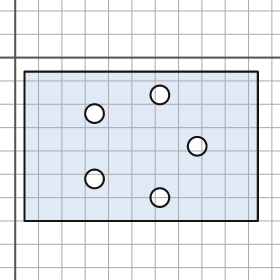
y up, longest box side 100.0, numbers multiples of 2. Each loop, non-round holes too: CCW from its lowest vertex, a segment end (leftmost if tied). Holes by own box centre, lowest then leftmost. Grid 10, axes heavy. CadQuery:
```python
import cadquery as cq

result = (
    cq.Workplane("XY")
    .moveTo(4.0, -70.0)
    .lineTo(104.0, -70.0)
    .lineTo(104.0, -6.0)
    .lineTo(4.0, -6.0)
    .close()
    .moveTo(62.0, -60.0)
    .circle(4.0)
    .moveTo(34.0, -52.0)
    .circle(4.0)
    .moveTo(78.0, -38.0)
    .circle(4.0)
    .moveTo(34.0, -24.0)
    .circle(4.0)
    .moveTo(62.0, -16.0)
    .circle(4.0)
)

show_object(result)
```